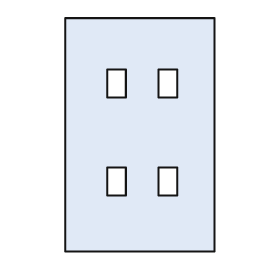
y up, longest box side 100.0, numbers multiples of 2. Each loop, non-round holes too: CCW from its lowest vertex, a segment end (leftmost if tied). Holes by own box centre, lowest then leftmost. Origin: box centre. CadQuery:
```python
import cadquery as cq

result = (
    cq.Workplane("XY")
    .moveTo(-32.0, -50.0)
    .lineTo(32.0, -50.0)
    .lineTo(32.0, 50.0)
    .lineTo(-32.0, 50.0)
    .close()
    .moveTo(-14.0, -26.0)
    .lineTo(-6.0, -26.0)
    .lineTo(-6.0, -14.0)
    .lineTo(-14.0, -14.0)
    .close()
    .moveTo(8.0, -26.0)
    .lineTo(16.0, -26.0)
    .lineTo(16.0, -14.0)
    .lineTo(8.0, -14.0)
    .close()
    .moveTo(-14.0, 16.0)
    .lineTo(-6.0, 16.0)
    .lineTo(-6.0, 28.0)
    .lineTo(-14.0, 28.0)
    .close()
    .moveTo(8.0, 16.0)
    .lineTo(16.0, 16.0)
    .lineTo(16.0, 28.0)
    .lineTo(8.0, 28.0)
    .close()
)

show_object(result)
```